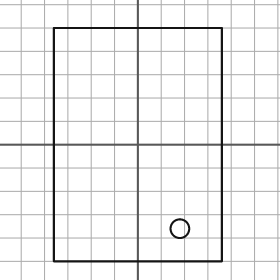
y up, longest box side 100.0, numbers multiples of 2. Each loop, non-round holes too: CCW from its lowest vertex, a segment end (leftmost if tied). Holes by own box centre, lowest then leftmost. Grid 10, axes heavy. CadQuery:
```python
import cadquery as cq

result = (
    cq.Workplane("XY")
    .moveTo(-36.0, -50.0)
    .lineTo(36.0, -50.0)
    .lineTo(36.0, 50.0)
    .lineTo(-36.0, 50.0)
    .close()
    .moveTo(18.0, -36.0)
    .circle(4.0)
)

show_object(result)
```